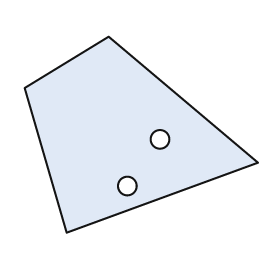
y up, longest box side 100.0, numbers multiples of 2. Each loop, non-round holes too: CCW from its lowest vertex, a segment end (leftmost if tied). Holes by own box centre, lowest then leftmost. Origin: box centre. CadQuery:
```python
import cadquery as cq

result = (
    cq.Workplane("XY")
    .moveTo(-32.0, -42.0)
    .lineTo(50.0, -12.0)
    .lineTo(-14.0, 42.0)
    .lineTo(-50.0, 20.0)
    .close()
    .moveTo(-6.0, -22.0)
    .circle(4.0)
    .moveTo(8.0, -2.0)
    .circle(4.0)
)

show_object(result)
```